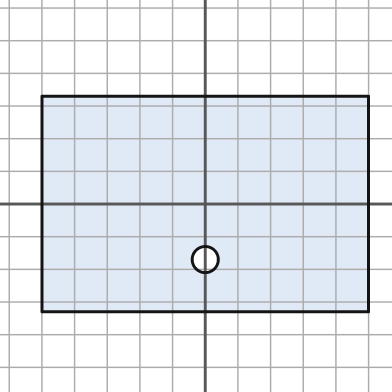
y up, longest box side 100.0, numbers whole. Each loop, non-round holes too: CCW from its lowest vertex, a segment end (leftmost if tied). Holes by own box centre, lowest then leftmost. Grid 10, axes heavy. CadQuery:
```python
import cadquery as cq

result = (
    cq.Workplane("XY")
    .moveTo(-50.0, -33.0)
    .lineTo(50.0, -33.0)
    .lineTo(50.0, 33.0)
    .lineTo(-50.0, 33.0)
    .close()
    .moveTo(0.0, -17.0)
    .circle(4.0)
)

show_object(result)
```